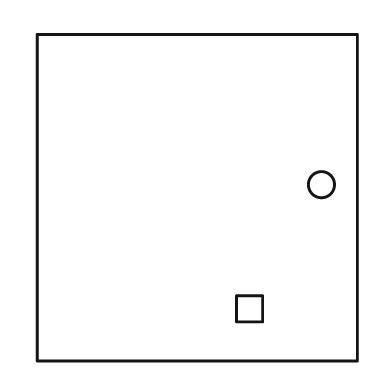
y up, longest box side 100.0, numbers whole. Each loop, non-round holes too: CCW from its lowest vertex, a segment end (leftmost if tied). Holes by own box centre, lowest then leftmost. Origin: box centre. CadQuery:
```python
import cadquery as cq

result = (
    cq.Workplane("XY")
    .moveTo(-49.0, -50.0)
    .lineTo(49.0, -50.0)
    .lineTo(49.0, 50.0)
    .lineTo(-49.0, 50.0)
    .close()
    .moveTo(12.0, -38.0)
    .lineTo(20.0, -38.0)
    .lineTo(20.0, -30.0)
    .lineTo(12.0, -30.0)
    .close()
    .moveTo(38.0, 4.0)
    .circle(4.0)
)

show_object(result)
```